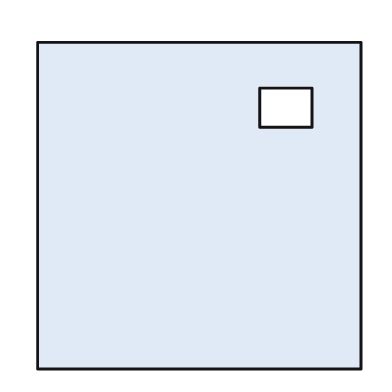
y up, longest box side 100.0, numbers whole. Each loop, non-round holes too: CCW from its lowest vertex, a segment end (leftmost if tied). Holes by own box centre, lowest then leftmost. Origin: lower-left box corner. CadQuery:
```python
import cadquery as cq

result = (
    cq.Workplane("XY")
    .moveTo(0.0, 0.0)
    .lineTo(99.0, 0.0)
    .lineTo(99.0, 100.0)
    .lineTo(0.0, 100.0)
    .close()
    .moveTo(68.0, 74.0)
    .lineTo(84.0, 74.0)
    .lineTo(84.0, 86.0)
    .lineTo(68.0, 86.0)
    .close()
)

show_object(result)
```